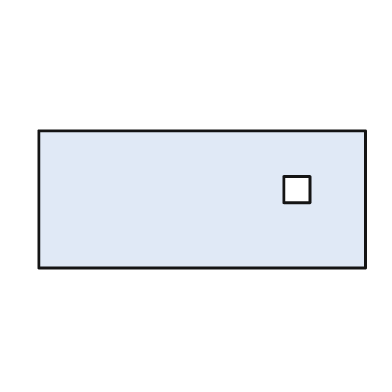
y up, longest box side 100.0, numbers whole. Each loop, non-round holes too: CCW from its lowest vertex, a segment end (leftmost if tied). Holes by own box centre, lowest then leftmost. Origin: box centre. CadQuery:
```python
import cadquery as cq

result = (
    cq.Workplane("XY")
    .moveTo(-50.0, -21.0)
    .lineTo(50.0, -21.0)
    .lineTo(50.0, 21.0)
    .lineTo(-50.0, 21.0)
    .close()
    .moveTo(25.0, -1.0)
    .lineTo(33.0, -1.0)
    .lineTo(33.0, 7.0)
    .lineTo(25.0, 7.0)
    .close()
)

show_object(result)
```